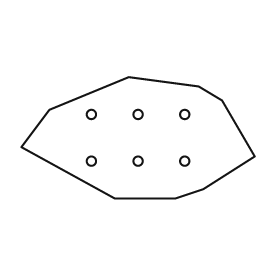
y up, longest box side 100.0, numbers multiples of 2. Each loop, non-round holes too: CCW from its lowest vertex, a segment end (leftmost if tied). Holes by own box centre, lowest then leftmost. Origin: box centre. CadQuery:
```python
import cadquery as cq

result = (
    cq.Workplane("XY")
    .moveTo(-10.0, -26.0)
    .lineTo(16.0, -26.0)
    .lineTo(28.0, -22.0)
    .lineTo(50.0, -8.0)
    .lineTo(36.0, 16.0)
    .lineTo(26.0, 22.0)
    .lineTo(-4.0, 26.0)
    .lineTo(-38.0, 12.0)
    .lineTo(-50.0, -4.0)
    .close()
    .moveTo(-20.0, -10.0)
    .circle(2.0)
    .moveTo(0.0, -10.0)
    .circle(2.0)
    .moveTo(20.0, -10.0)
    .circle(2.0)
    .moveTo(-20.0, 10.0)
    .circle(2.0)
    .moveTo(0.0, 10.0)
    .circle(2.0)
    .moveTo(20.0, 10.0)
    .circle(2.0)
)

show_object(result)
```